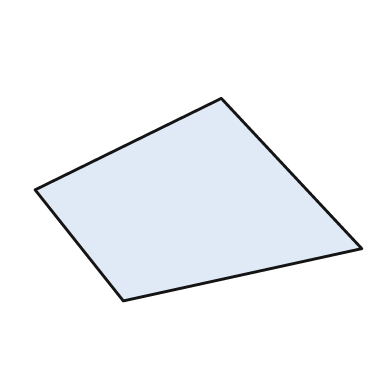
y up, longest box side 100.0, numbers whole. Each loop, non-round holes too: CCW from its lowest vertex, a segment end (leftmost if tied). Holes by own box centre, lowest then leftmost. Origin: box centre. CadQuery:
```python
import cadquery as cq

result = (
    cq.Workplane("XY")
    .moveTo(-23.0, -31.0)
    .lineTo(50.0, -15.0)
    .lineTo(7.0, 31.0)
    .lineTo(-50.0, 3.0)
    .close()
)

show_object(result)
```